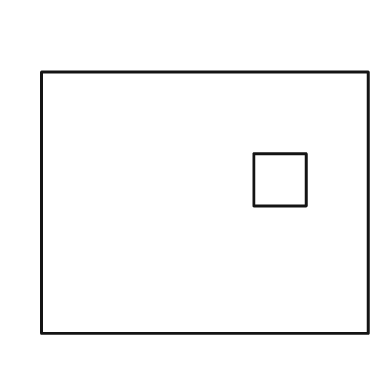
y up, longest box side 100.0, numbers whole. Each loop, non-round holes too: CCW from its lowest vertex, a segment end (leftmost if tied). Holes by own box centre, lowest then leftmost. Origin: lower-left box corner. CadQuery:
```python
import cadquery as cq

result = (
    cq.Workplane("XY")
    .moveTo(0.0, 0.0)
    .lineTo(100.0, 0.0)
    .lineTo(100.0, 80.0)
    .lineTo(0.0, 80.0)
    .close()
    .moveTo(65.0, 39.0)
    .lineTo(81.0, 39.0)
    .lineTo(81.0, 55.0)
    .lineTo(65.0, 55.0)
    .close()
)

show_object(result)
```